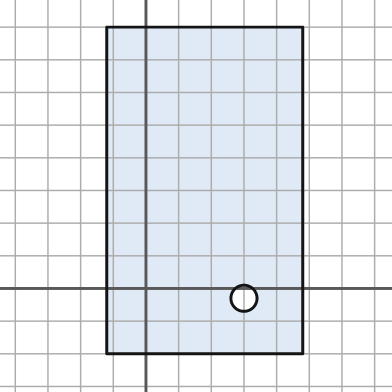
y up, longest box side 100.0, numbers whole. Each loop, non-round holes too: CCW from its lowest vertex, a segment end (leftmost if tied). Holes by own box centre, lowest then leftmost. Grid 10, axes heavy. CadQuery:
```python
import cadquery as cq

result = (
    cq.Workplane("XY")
    .moveTo(-12.0, -20.0)
    .lineTo(48.0, -20.0)
    .lineTo(48.0, 80.0)
    .lineTo(-12.0, 80.0)
    .close()
    .moveTo(30.0, -3.0)
    .circle(4.0)
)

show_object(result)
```